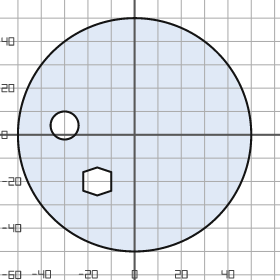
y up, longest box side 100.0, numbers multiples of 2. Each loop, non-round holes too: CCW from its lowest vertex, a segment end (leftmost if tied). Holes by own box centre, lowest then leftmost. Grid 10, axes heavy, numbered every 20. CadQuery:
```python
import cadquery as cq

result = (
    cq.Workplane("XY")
    .moveTo(0.0, 0.0)
    .circle(50.0)
    .moveTo(-16.0, -26.0)
    .lineTo(-10.0, -24.0)
    .lineTo(-10.0, -16.0)
    .lineTo(-16.0, -14.0)
    .lineTo(-22.0, -16.0)
    .lineTo(-22.0, -24.0)
    .close()
    .moveTo(-30.0, 4.0)
    .circle(6.0)
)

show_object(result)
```